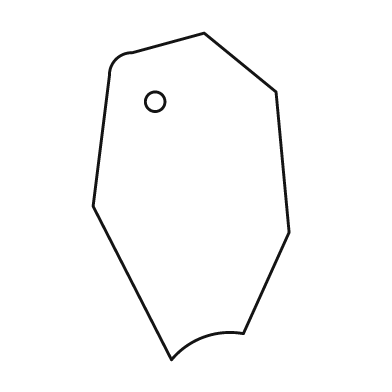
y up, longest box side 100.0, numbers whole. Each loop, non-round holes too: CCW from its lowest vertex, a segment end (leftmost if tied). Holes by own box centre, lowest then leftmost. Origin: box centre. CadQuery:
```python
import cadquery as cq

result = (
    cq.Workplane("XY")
    .moveTo(-6.0, -50.0)
    .threePointArc((4.0, -43.0), (16.0, -42.0))
    .lineTo(30.0, -11.0)
    .lineTo(26.0, 32.0)
    .lineTo(4.0, 50.0)
    .lineTo(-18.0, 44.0)
    .threePointArc((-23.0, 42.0), (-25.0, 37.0))
    .lineTo(-30.0, -3.0)
    .close()
    .moveTo(-11.0, 29.0)
    .circle(3.0)
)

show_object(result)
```